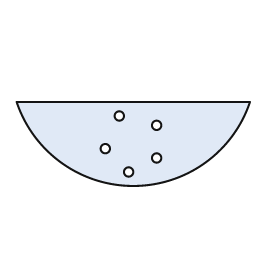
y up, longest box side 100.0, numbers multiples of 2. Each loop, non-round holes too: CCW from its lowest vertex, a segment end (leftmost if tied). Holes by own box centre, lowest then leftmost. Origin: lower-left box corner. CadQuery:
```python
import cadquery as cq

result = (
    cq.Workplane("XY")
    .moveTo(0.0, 36.0)
    .threePointArc((50.0, 0.0), (100.0, 36.0))
    .close()
    .moveTo(48.0, 6.0)
    .circle(2.0)
    .moveTo(60.0, 12.0)
    .circle(2.0)
    .moveTo(38.0, 16.0)
    .circle(2.0)
    .moveTo(60.0, 26.0)
    .circle(2.0)
    .moveTo(44.0, 30.0)
    .circle(2.0)
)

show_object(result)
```